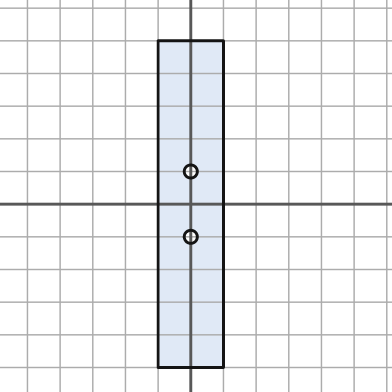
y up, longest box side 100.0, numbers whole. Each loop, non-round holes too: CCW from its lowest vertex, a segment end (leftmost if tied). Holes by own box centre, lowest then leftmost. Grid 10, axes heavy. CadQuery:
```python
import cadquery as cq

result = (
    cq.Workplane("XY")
    .moveTo(-10.0, -50.0)
    .lineTo(10.0, -50.0)
    .lineTo(10.0, 50.0)
    .lineTo(-10.0, 50.0)
    .close()
    .moveTo(0.0, -10.0)
    .circle(2.0)
    .moveTo(0.0, 10.0)
    .circle(2.0)
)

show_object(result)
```